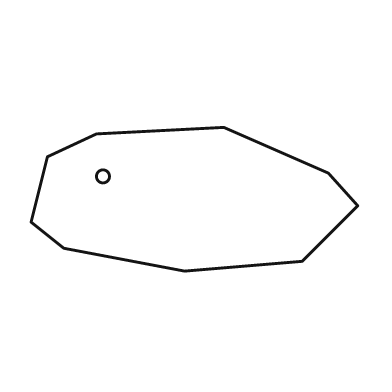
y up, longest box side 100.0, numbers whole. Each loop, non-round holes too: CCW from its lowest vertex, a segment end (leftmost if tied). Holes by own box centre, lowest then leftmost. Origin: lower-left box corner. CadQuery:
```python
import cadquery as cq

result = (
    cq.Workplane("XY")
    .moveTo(47.0, 0.0)
    .lineTo(83.0, 3.0)
    .lineTo(100.0, 20.0)
    .lineTo(91.0, 30.0)
    .lineTo(59.0, 44.0)
    .lineTo(20.0, 42.0)
    .lineTo(5.0, 35.0)
    .lineTo(0.0, 15.0)
    .lineTo(10.0, 7.0)
    .close()
    .moveTo(22.0, 29.0)
    .circle(2.0)
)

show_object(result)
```